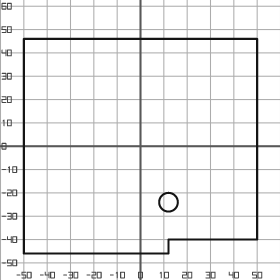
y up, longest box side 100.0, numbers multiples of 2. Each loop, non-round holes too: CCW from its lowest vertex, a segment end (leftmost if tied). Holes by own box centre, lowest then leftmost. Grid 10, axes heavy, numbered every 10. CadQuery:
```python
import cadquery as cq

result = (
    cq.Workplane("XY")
    .moveTo(-50.0, -46.0)
    .lineTo(12.0, -46.0)
    .lineTo(12.0, -40.0)
    .lineTo(50.0, -40.0)
    .lineTo(50.0, 46.0)
    .lineTo(-50.0, 46.0)
    .close()
    .moveTo(12.0, -24.0)
    .circle(4.0)
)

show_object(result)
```